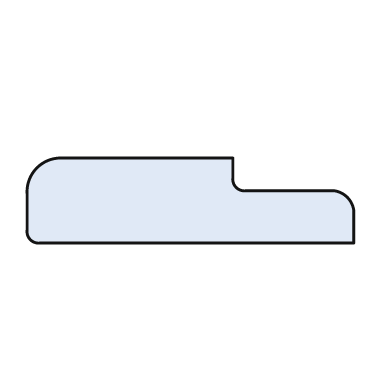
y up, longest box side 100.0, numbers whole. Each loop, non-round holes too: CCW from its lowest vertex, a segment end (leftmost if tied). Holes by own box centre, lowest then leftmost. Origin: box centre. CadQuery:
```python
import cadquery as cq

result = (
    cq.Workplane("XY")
    .moveTo(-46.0, -13.0)
    .lineTo(50.0, -13.0)
    .lineTo(50.0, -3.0)
    .threePointArc((48.0, 1.0), (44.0, 3.0))
    .lineTo(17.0, 3.0)
    .threePointArc((14.0, 4.0), (13.0, 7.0))
    .lineTo(13.0, 13.0)
    .lineTo(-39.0, 13.0)
    .threePointArc((-47.0, 10.0), (-50.0, 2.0))
    .lineTo(-50.0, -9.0)
    .threePointArc((-49.0, -12.0), (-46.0, -13.0))
    .close()
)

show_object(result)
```